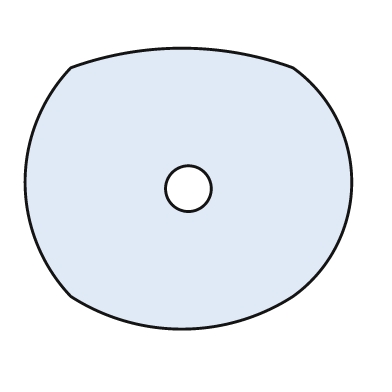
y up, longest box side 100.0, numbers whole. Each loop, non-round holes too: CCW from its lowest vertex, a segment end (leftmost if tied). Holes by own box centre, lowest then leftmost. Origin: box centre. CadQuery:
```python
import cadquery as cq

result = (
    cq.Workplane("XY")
    .moveTo(-36.0, -33.0)
    .threePointArc((-2.0, -43.0), (32.0, -33.0))
    .threePointArc((50.0, 2.0), (32.0, 37.0))
    .threePointArc((-2.0, 43.0), (-36.0, 37.0))
    .threePointArc((-50.0, 2.0), (-36.0, -33.0))
    .close()
    .moveTo(0.0, 0.0)
    .circle(7.0)
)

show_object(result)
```